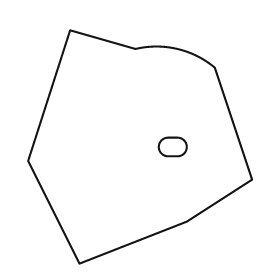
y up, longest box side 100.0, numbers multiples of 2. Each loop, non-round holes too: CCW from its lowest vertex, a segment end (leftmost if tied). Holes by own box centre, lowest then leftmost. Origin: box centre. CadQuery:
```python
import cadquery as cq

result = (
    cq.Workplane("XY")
    .moveTo(-26.0, -50.0)
    .lineTo(20.0, -32.0)
    .lineTo(48.0, -14.0)
    .lineTo(32.0, 34.0)
    .threePointArc((16.0, 42.0), (-2.0, 42.0))
    .lineTo(-30.0, 50.0)
    .lineTo(-48.0, -6.0)
    .close()
    .moveTo(12.0, -4.0)
    .lineTo(16.0, -4.0)
    .threePointArc((20.0, 0.0), (16.0, 4.0))
    .lineTo(12.0, 4.0)
    .threePointArc((8.0, 0.0), (12.0, -4.0))
    .close()
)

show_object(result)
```